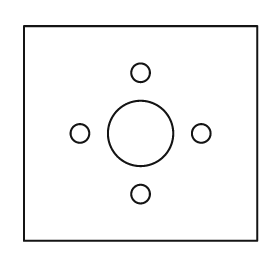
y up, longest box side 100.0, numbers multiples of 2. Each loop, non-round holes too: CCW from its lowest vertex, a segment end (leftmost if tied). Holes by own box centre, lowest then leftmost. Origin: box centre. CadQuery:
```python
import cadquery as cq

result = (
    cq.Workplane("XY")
    .moveTo(-50.0, -46.0)
    .lineTo(50.0, -46.0)
    .lineTo(50.0, 46.0)
    .lineTo(-50.0, 46.0)
    .close()
    .moveTo(0.0, -26.0)
    .circle(4.0)
    .moveTo(-26.0, 0.0)
    .circle(4.0)
    .moveTo(0.0, 0.0)
    .circle(14.0)
    .moveTo(26.0, 0.0)
    .circle(4.0)
    .moveTo(0.0, 26.0)
    .circle(4.0)
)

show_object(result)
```